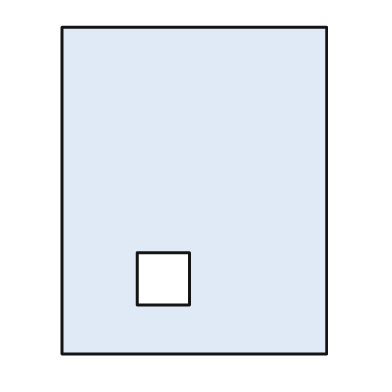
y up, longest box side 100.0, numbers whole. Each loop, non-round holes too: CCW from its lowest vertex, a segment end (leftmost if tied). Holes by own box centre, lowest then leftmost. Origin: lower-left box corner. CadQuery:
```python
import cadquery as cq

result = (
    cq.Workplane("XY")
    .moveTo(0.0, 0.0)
    .lineTo(81.0, 0.0)
    .lineTo(81.0, 100.0)
    .lineTo(0.0, 100.0)
    .close()
    .moveTo(23.0, 15.0)
    .lineTo(39.0, 15.0)
    .lineTo(39.0, 31.0)
    .lineTo(23.0, 31.0)
    .close()
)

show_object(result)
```